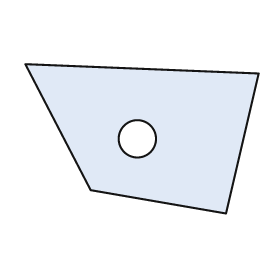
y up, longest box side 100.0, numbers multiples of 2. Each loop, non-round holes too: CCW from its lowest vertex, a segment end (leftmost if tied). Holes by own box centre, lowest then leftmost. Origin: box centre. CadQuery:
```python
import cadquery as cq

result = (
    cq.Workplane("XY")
    .moveTo(36.0, -32.0)
    .lineTo(50.0, 28.0)
    .lineTo(-50.0, 32.0)
    .lineTo(-22.0, -22.0)
    .close()
    .moveTo(-2.0, 0.0)
    .circle(8.0)
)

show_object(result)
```